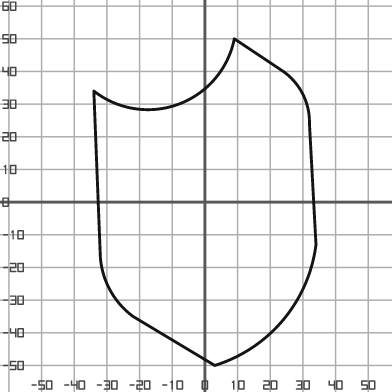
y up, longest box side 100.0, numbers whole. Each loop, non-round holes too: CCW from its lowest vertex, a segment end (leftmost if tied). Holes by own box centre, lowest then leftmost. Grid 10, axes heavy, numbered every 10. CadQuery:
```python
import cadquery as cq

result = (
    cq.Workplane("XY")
    .moveTo(3.0, -50.0)
    .threePointArc((24.0, -36.0), (34.0, -13.0))
    .lineTo(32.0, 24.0)
    .threePointArc((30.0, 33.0), (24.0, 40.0))
    .lineTo(9.0, 50.0)
    .threePointArc((-8.0, 30.0), (-34.0, 34.0))
    .lineTo(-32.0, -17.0)
    .threePointArc((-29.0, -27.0), (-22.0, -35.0))
    .close()
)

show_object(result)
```